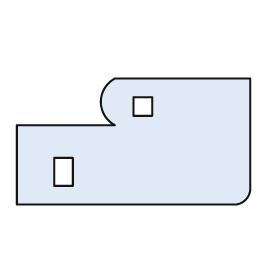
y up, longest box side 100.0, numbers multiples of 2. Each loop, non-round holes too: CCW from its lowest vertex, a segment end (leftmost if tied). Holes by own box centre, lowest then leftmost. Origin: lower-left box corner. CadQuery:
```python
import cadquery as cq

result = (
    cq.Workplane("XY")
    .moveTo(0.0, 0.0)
    .lineTo(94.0, 0.0)
    .threePointArc((98.0, 2.0), (100.0, 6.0))
    .lineTo(100.0, 54.0)
    .lineTo(42.0, 54.0)
    .threePointArc((36.0, 44.0), (42.0, 34.0))
    .lineTo(0.0, 34.0)
    .close()
    .moveTo(16.0, 8.0)
    .lineTo(24.0, 8.0)
    .lineTo(24.0, 20.0)
    .lineTo(16.0, 20.0)
    .close()
    .moveTo(50.0, 38.0)
    .lineTo(58.0, 38.0)
    .lineTo(58.0, 46.0)
    .lineTo(50.0, 46.0)
    .close()
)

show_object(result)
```